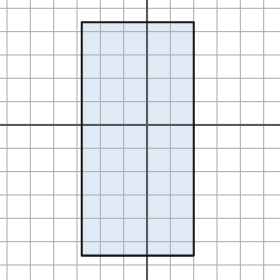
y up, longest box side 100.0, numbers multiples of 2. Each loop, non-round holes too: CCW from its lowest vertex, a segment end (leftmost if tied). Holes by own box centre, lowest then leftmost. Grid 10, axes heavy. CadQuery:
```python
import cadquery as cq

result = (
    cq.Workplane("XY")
    .moveTo(-28.0, -56.0)
    .lineTo(20.0, -56.0)
    .lineTo(20.0, 44.0)
    .lineTo(-28.0, 44.0)
    .close()
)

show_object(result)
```